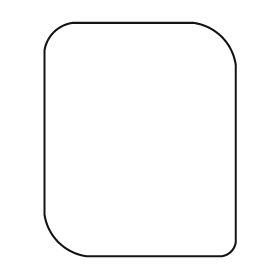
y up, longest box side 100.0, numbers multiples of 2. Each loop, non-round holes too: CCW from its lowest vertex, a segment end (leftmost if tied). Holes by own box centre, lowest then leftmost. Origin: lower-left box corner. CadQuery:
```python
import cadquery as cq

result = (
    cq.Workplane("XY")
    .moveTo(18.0, 0.0)
    .lineTo(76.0, 0.0)
    .threePointArc((80.0, 2.0), (82.0, 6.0))
    .lineTo(82.0, 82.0)
    .threePointArc((76.0, 94.0), (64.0, 100.0))
    .lineTo(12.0, 100.0)
    .threePointArc((4.0, 96.0), (0.0, 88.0))
    .lineTo(0.0, 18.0)
    .threePointArc((6.0, 6.0), (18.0, 0.0))
    .close()
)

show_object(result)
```